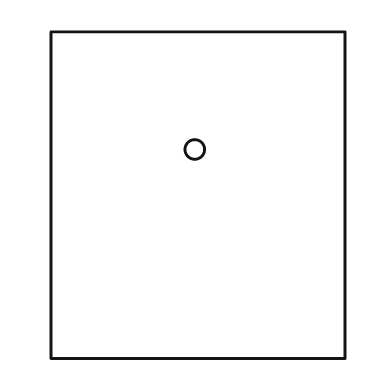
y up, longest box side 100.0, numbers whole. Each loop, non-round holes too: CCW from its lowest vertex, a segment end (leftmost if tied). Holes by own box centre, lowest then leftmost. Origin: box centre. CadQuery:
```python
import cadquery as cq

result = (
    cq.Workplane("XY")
    .moveTo(-45.0, -50.0)
    .lineTo(45.0, -50.0)
    .lineTo(45.0, 50.0)
    .lineTo(-45.0, 50.0)
    .close()
    .moveTo(-1.0, 14.0)
    .circle(3.0)
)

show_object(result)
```